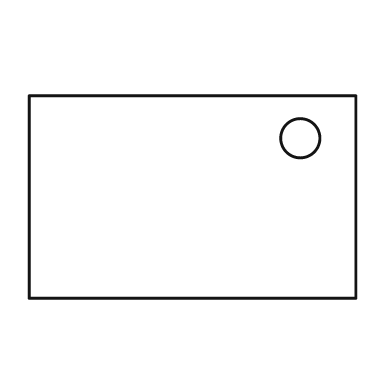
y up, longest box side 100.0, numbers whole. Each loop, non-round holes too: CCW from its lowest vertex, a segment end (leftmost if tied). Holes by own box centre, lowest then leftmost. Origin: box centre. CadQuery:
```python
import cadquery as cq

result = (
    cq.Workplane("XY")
    .moveTo(-50.0, -31.0)
    .lineTo(50.0, -31.0)
    .lineTo(50.0, 31.0)
    .lineTo(-50.0, 31.0)
    .close()
    .moveTo(33.0, 18.0)
    .circle(6.0)
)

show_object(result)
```